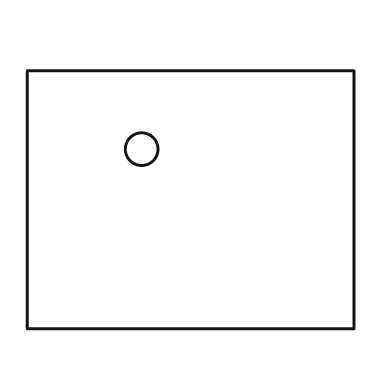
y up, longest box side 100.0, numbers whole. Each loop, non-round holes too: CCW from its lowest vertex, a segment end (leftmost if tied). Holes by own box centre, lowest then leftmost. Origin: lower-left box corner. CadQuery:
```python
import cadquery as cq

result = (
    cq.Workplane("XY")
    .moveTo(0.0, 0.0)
    .lineTo(100.0, 0.0)
    .lineTo(100.0, 79.0)
    .lineTo(0.0, 79.0)
    .close()
    .moveTo(35.0, 55.0)
    .circle(5.0)
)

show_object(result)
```